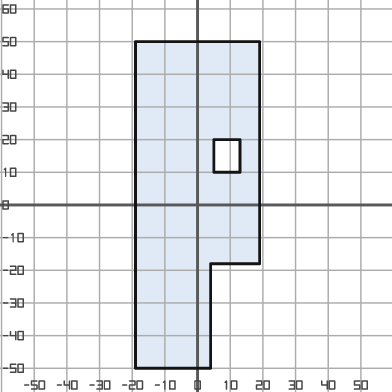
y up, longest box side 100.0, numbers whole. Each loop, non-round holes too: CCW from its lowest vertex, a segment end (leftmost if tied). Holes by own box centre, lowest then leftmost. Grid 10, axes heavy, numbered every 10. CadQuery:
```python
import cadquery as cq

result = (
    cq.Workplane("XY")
    .moveTo(-19.0, -50.0)
    .lineTo(4.0, -50.0)
    .lineTo(4.0, -18.0)
    .lineTo(19.0, -18.0)
    .lineTo(19.0, 50.0)
    .lineTo(-19.0, 50.0)
    .close()
    .moveTo(5.0, 10.0)
    .lineTo(13.0, 10.0)
    .lineTo(13.0, 20.0)
    .lineTo(5.0, 20.0)
    .close()
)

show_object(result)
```